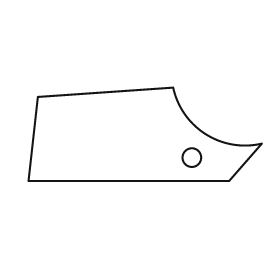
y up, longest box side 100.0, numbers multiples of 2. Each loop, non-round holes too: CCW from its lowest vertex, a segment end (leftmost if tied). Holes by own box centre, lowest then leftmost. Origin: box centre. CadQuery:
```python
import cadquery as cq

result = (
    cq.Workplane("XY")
    .moveTo(-50.0, -20.0)
    .lineTo(36.0, -20.0)
    .lineTo(50.0, -4.0)
    .threePointArc((26.0, 0.0), (12.0, 20.0))
    .lineTo(-46.0, 16.0)
    .close()
    .moveTo(20.0, -10.0)
    .circle(4.0)
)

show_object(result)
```